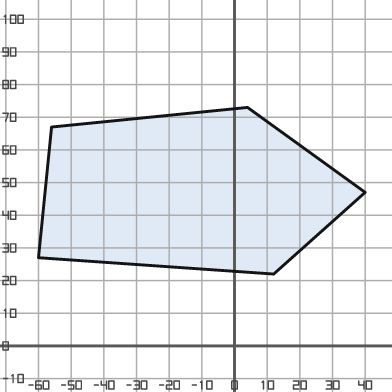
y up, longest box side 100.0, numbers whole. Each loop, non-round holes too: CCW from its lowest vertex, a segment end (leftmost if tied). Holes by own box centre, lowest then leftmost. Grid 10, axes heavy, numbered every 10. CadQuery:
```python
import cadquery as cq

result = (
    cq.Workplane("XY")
    .moveTo(12.0, 22.0)
    .lineTo(40.0, 47.0)
    .lineTo(4.0, 73.0)
    .lineTo(-56.0, 67.0)
    .lineTo(-60.0, 27.0)
    .close()
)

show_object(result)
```